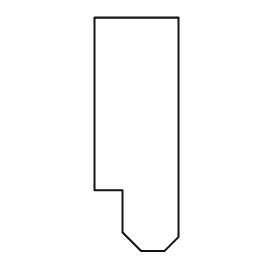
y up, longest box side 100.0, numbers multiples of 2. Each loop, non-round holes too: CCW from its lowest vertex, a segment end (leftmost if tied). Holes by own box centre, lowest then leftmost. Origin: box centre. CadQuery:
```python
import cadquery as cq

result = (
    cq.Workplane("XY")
    .moveTo(2.0, -50.0)
    .lineTo(12.0, -50.0)
    .lineTo(18.0, -44.0)
    .lineTo(18.0, 50.0)
    .lineTo(-18.0, 50.0)
    .lineTo(-18.0, -24.0)
    .lineTo(-6.0, -24.0)
    .lineTo(-6.0, -42.0)
    .close()
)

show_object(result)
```